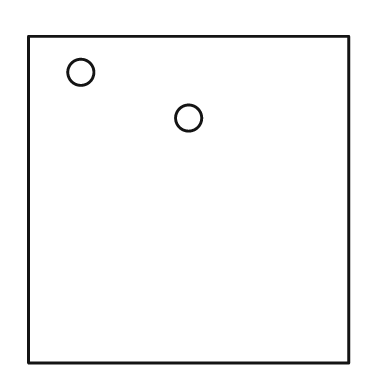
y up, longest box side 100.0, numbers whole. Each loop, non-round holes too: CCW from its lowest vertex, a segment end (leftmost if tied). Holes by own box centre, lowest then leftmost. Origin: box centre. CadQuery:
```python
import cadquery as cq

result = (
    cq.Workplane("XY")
    .moveTo(-49.0, -50.0)
    .lineTo(49.0, -50.0)
    .lineTo(49.0, 50.0)
    .lineTo(-49.0, 50.0)
    .close()
    .moveTo(0.0, 25.0)
    .circle(4.0)
    .moveTo(-33.0, 39.0)
    .circle(4.0)
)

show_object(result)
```